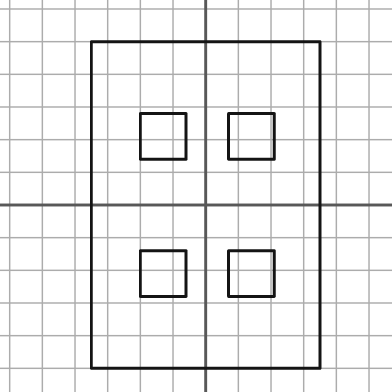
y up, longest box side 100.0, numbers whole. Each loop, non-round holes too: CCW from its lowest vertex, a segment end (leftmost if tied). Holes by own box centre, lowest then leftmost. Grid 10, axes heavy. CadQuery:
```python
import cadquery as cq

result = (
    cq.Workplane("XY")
    .moveTo(-35.0, -50.0)
    .lineTo(35.0, -50.0)
    .lineTo(35.0, 50.0)
    .lineTo(-35.0, 50.0)
    .close()
    .moveTo(-20.0, -28.0)
    .lineTo(-6.0, -28.0)
    .lineTo(-6.0, -14.0)
    .lineTo(-20.0, -14.0)
    .close()
    .moveTo(7.0, -28.0)
    .lineTo(21.0, -28.0)
    .lineTo(21.0, -14.0)
    .lineTo(7.0, -14.0)
    .close()
    .moveTo(-20.0, 14.0)
    .lineTo(-6.0, 14.0)
    .lineTo(-6.0, 28.0)
    .lineTo(-20.0, 28.0)
    .close()
    .moveTo(7.0, 14.0)
    .lineTo(21.0, 14.0)
    .lineTo(21.0, 28.0)
    .lineTo(7.0, 28.0)
    .close()
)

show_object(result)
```